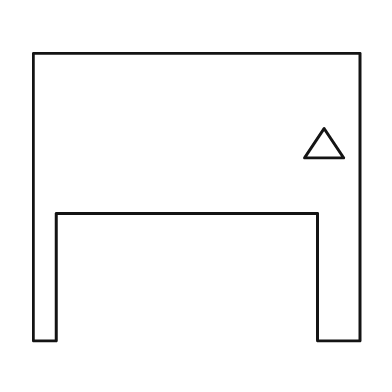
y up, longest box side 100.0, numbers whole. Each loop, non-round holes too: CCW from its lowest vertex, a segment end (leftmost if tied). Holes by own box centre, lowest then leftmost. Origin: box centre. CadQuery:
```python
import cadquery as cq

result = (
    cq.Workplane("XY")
    .moveTo(-50.0, -44.0)
    .lineTo(-43.0, -44.0)
    .lineTo(-43.0, -5.0)
    .lineTo(37.0, -5.0)
    .lineTo(37.0, -44.0)
    .lineTo(50.0, -44.0)
    .lineTo(50.0, 44.0)
    .lineTo(-50.0, 44.0)
    .close()
    .moveTo(33.0, 12.0)
    .lineTo(45.0, 12.0)
    .lineTo(39.0, 21.0)
    .close()
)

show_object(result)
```